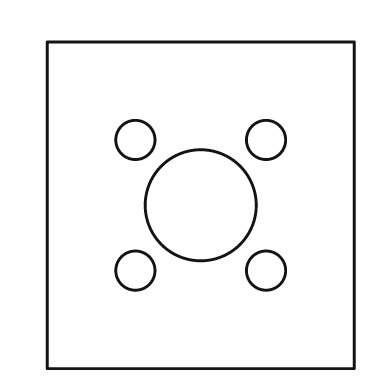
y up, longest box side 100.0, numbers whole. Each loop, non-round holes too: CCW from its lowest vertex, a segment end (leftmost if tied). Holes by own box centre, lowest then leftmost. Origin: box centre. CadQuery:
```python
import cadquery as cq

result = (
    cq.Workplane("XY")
    .moveTo(-47.0, -50.0)
    .lineTo(47.0, -50.0)
    .lineTo(47.0, 50.0)
    .lineTo(-47.0, 50.0)
    .close()
    .moveTo(-20.0, -20.0)
    .circle(6.0)
    .moveTo(20.0, -20.0)
    .circle(6.0)
    .moveTo(0.0, 0.0)
    .circle(17.0)
    .moveTo(-20.0, 20.0)
    .circle(6.0)
    .moveTo(20.0, 20.0)
    .circle(6.0)
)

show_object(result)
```